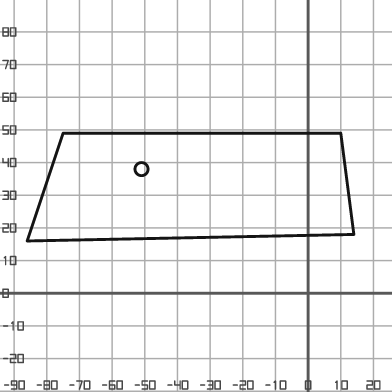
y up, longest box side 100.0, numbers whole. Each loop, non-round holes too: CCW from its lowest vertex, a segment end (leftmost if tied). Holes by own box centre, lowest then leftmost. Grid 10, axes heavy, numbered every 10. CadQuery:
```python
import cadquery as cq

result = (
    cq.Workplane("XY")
    .moveTo(-86.0, 16.0)
    .lineTo(14.0, 18.0)
    .lineTo(10.0, 49.0)
    .lineTo(-75.0, 49.0)
    .close()
    .moveTo(-51.0, 38.0)
    .circle(2.0)
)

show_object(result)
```